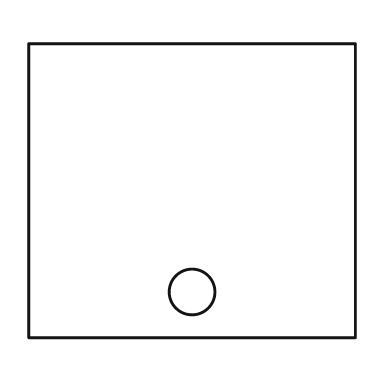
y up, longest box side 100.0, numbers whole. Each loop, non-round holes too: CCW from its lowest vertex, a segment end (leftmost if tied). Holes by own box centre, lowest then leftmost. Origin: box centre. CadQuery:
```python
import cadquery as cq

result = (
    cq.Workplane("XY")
    .moveTo(-50.0, -45.0)
    .lineTo(50.0, -45.0)
    .lineTo(50.0, 45.0)
    .lineTo(-50.0, 45.0)
    .close()
    .moveTo(0.0, -31.0)
    .circle(7.0)
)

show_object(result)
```